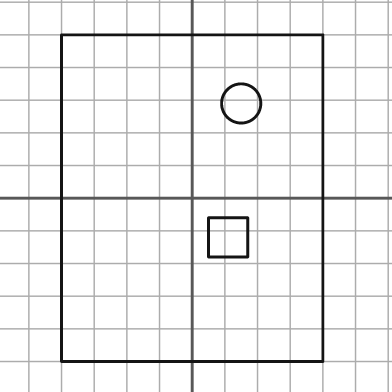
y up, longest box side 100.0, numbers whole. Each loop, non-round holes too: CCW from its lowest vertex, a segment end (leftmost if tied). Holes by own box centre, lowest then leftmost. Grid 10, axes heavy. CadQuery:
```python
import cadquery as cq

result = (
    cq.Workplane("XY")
    .moveTo(-40.0, -50.0)
    .lineTo(40.0, -50.0)
    .lineTo(40.0, 50.0)
    .lineTo(-40.0, 50.0)
    .close()
    .moveTo(5.0, -18.0)
    .lineTo(17.0, -18.0)
    .lineTo(17.0, -6.0)
    .lineTo(5.0, -6.0)
    .close()
    .moveTo(15.0, 29.0)
    .circle(6.0)
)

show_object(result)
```